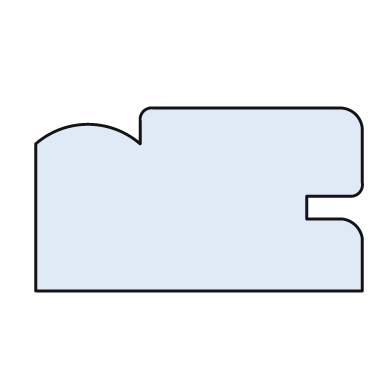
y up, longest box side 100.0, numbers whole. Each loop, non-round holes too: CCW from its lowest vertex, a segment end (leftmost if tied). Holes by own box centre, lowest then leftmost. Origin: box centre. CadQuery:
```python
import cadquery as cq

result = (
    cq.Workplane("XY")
    .moveTo(-50.0, -28.0)
    .lineTo(50.0, -28.0)
    .lineTo(50.0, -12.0)
    .threePointArc((48.0, -8.0), (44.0, -6.0))
    .lineTo(33.0, -6.0)
    .lineTo(33.0, 1.0)
    .lineTo(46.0, 1.0)
    .threePointArc((49.0, 2.0), (50.0, 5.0))
    .lineTo(50.0, 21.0)
    .threePointArc((48.0, 26.0), (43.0, 28.0))
    .lineTo(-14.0, 28.0)
    .threePointArc((-17.0, 27.0), (-18.0, 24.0))
    .lineTo(-18.0, 17.0)
    .threePointArc((-34.0, 23.0), (-50.0, 17.0))
    .close()
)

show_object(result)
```